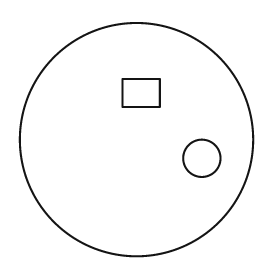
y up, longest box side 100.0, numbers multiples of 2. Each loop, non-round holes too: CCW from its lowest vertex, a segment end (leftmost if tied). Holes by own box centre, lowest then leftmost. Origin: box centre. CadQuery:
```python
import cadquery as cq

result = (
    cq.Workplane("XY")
    .moveTo(0.0, 0.0)
    .circle(50.0)
    .moveTo(28.0, -8.0)
    .circle(8.0)
    .moveTo(-6.0, 14.0)
    .lineTo(10.0, 14.0)
    .lineTo(10.0, 26.0)
    .lineTo(-6.0, 26.0)
    .close()
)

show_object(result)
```